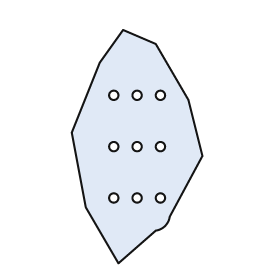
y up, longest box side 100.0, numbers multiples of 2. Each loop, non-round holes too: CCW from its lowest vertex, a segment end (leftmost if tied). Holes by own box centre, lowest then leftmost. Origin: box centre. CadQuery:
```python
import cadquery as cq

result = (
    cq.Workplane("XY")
    .moveTo(-8.0, -50.0)
    .lineTo(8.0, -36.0)
    .threePointArc((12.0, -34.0), (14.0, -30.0))
    .lineTo(28.0, -4.0)
    .lineTo(22.0, 20.0)
    .lineTo(8.0, 44.0)
    .lineTo(-6.0, 50.0)
    .lineTo(-16.0, 36.0)
    .lineTo(-28.0, 6.0)
    .lineTo(-22.0, -26.0)
    .close()
    .moveTo(-10.0, -22.0)
    .circle(2.0)
    .moveTo(0.0, -22.0)
    .circle(2.0)
    .moveTo(10.0, -22.0)
    .circle(2.0)
    .moveTo(-10.0, 0.0)
    .circle(2.0)
    .moveTo(0.0, 0.0)
    .circle(2.0)
    .moveTo(10.0, 0.0)
    .circle(2.0)
    .moveTo(-10.0, 22.0)
    .circle(2.0)
    .moveTo(0.0, 22.0)
    .circle(2.0)
    .moveTo(10.0, 22.0)
    .circle(2.0)
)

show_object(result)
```